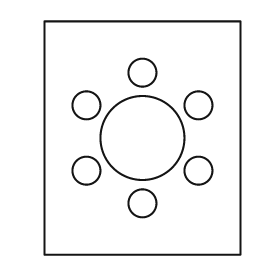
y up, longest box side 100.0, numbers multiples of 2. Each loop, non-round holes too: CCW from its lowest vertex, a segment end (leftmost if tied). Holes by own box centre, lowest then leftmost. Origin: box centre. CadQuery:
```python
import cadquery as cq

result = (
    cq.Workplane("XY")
    .moveTo(-42.0, -50.0)
    .lineTo(42.0, -50.0)
    .lineTo(42.0, 50.0)
    .lineTo(-42.0, 50.0)
    .close()
    .moveTo(0.0, -28.0)
    .circle(6.0)
    .moveTo(-24.0, -14.0)
    .circle(6.0)
    .moveTo(24.0, -14.0)
    .circle(6.0)
    .moveTo(0.0, 0.0)
    .circle(18.0)
    .moveTo(-24.0, 14.0)
    .circle(6.0)
    .moveTo(24.0, 14.0)
    .circle(6.0)
    .moveTo(0.0, 28.0)
    .circle(6.0)
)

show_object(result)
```